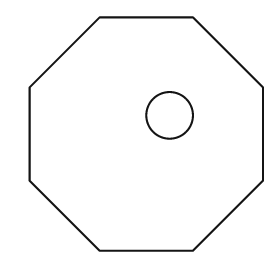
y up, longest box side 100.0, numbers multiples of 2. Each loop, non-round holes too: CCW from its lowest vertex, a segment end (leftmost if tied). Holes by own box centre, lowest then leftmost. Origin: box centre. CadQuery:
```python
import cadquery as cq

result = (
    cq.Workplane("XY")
    .moveTo(-20.0, -50.0)
    .lineTo(20.0, -50.0)
    .lineTo(50.0, -20.0)
    .lineTo(50.0, 20.0)
    .lineTo(20.0, 50.0)
    .lineTo(-20.0, 50.0)
    .lineTo(-50.0, 20.0)
    .lineTo(-50.0, -20.0)
    .close()
    .moveTo(10.0, 8.0)
    .circle(10.0)
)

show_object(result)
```